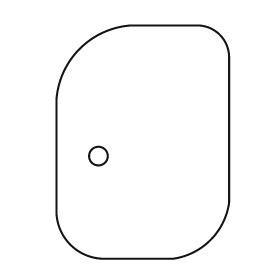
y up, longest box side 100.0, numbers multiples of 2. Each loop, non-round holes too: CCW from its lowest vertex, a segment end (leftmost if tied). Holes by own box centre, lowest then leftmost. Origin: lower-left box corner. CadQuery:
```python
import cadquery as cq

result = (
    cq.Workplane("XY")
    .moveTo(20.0, 0.0)
    .lineTo(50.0, 0.0)
    .threePointArc((66.0, 8.0), (74.0, 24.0))
    .lineTo(74.0, 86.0)
    .threePointArc((70.0, 96.0), (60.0, 100.0))
    .lineTo(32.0, 100.0)
    .threePointArc((10.0, 90.0), (0.0, 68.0))
    .lineTo(0.0, 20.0)
    .threePointArc((6.0, 6.0), (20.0, 0.0))
    .close()
    .moveTo(18.0, 44.0)
    .circle(4.0)
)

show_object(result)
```